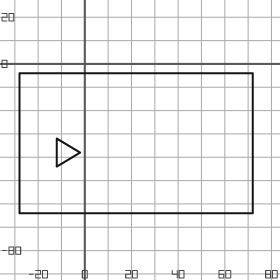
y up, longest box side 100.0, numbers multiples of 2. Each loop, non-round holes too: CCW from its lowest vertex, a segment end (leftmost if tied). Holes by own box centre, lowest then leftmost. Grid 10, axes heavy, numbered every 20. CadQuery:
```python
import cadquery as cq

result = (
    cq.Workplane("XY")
    .moveTo(-28.0, -64.0)
    .lineTo(72.0, -64.0)
    .lineTo(72.0, -4.0)
    .lineTo(-28.0, -4.0)
    .close()
    .moveTo(-12.0, -44.0)
    .lineTo(-2.0, -38.0)
    .lineTo(-12.0, -32.0)
    .close()
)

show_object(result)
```